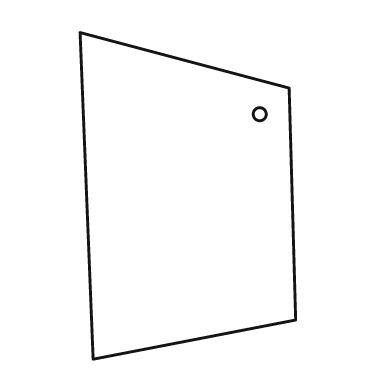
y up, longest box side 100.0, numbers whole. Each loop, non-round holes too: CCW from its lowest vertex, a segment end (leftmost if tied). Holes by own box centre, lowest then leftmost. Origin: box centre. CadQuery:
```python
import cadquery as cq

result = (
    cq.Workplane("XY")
    .moveTo(-29.0, -50.0)
    .lineTo(33.0, -38.0)
    .lineTo(31.0, 33.0)
    .lineTo(-33.0, 50.0)
    .close()
    .moveTo(22.0, 25.0)
    .circle(2.0)
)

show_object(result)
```